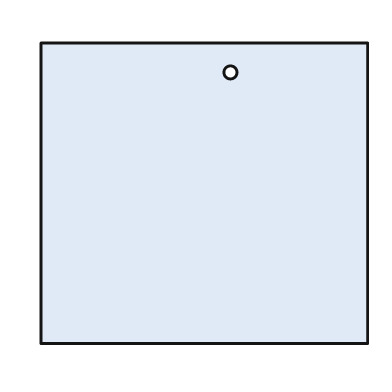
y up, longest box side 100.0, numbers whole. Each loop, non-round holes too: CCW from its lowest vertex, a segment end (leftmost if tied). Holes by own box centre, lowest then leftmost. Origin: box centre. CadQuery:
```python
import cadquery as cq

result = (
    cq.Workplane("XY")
    .moveTo(-50.0, -46.0)
    .lineTo(50.0, -46.0)
    .lineTo(50.0, 46.0)
    .lineTo(-50.0, 46.0)
    .close()
    .moveTo(8.0, 37.0)
    .circle(2.0)
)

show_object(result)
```